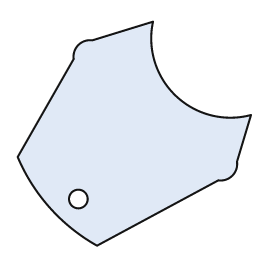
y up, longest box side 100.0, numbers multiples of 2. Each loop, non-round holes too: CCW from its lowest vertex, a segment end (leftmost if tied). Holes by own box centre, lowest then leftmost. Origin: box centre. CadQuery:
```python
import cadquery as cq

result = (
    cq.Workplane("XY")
    .moveTo(-16.0, -48.0)
    .lineTo(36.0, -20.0)
    .threePointArc((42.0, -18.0), (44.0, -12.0))
    .lineTo(50.0, 8.0)
    .threePointArc((18.0, 16.0), (8.0, 48.0))
    .lineTo(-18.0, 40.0)
    .threePointArc((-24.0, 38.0), (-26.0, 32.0))
    .lineTo(-50.0, -10.0)
    .threePointArc((-36.0, -32.0), (-16.0, -48.0))
    .close()
    .moveTo(-24.0, -28.0)
    .circle(4.0)
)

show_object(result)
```